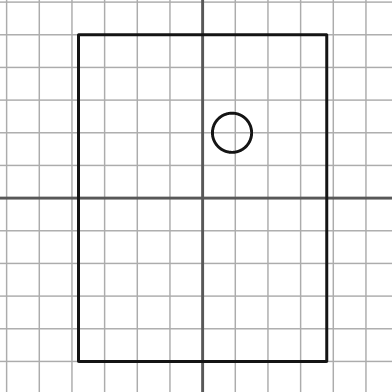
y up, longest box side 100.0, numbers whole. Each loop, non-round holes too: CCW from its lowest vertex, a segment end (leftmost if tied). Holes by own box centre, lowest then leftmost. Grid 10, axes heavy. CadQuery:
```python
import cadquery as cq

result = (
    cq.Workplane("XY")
    .moveTo(-38.0, -50.0)
    .lineTo(38.0, -50.0)
    .lineTo(38.0, 50.0)
    .lineTo(-38.0, 50.0)
    .close()
    .moveTo(9.0, 20.0)
    .circle(6.0)
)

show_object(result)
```